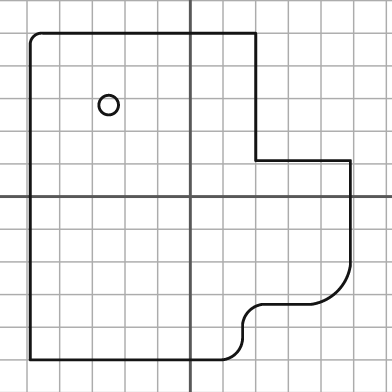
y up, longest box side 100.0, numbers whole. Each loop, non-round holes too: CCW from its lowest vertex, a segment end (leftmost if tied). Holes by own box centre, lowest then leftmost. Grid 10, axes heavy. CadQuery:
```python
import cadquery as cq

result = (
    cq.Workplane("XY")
    .moveTo(-49.0, -50.0)
    .lineTo(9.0, -50.0)
    .threePointArc((14.0, -48.0), (16.0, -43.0))
    .lineTo(16.0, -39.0)
    .threePointArc((18.0, -35.0), (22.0, -33.0))
    .lineTo(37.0, -33.0)
    .threePointArc((45.0, -29.0), (49.0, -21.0))
    .lineTo(49.0, 11.0)
    .lineTo(20.0, 11.0)
    .lineTo(20.0, 50.0)
    .lineTo(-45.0, 50.0)
    .threePointArc((-48.0, 49.0), (-49.0, 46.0))
    .close()
    .moveTo(-25.0, 28.0)
    .circle(3.0)
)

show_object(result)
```